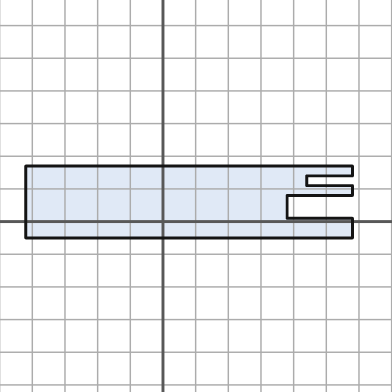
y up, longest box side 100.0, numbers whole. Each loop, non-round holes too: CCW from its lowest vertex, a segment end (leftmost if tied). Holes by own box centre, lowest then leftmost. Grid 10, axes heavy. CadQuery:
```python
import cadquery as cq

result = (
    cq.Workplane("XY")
    .moveTo(-42.0, -5.0)
    .lineTo(58.0, -5.0)
    .lineTo(58.0, 1.0)
    .lineTo(38.0, 1.0)
    .lineTo(38.0, 8.0)
    .lineTo(58.0, 8.0)
    .lineTo(58.0, 11.0)
    .lineTo(44.0, 11.0)
    .lineTo(44.0, 14.0)
    .lineTo(58.0, 14.0)
    .lineTo(58.0, 17.0)
    .lineTo(-42.0, 17.0)
    .close()
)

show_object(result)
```